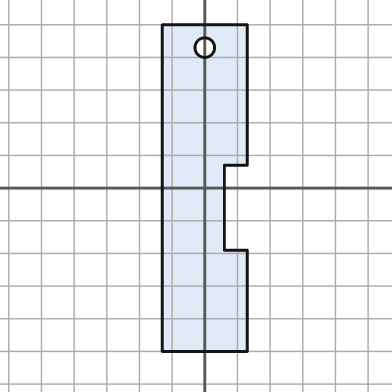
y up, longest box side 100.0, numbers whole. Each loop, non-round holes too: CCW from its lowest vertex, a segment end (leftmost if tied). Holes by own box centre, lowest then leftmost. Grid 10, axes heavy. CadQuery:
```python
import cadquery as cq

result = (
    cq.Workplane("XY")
    .moveTo(-13.0, -50.0)
    .lineTo(13.0, -50.0)
    .lineTo(13.0, -19.0)
    .lineTo(6.0, -19.0)
    .lineTo(6.0, 7.0)
    .lineTo(13.0, 7.0)
    .lineTo(13.0, 50.0)
    .lineTo(-13.0, 50.0)
    .close()
    .moveTo(0.0, 43.0)
    .circle(3.0)
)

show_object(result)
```